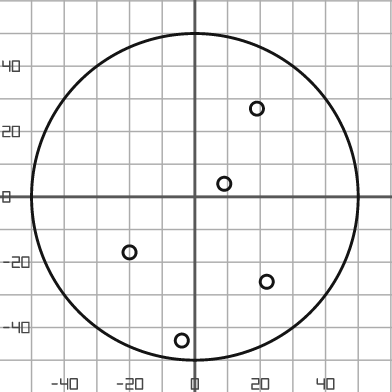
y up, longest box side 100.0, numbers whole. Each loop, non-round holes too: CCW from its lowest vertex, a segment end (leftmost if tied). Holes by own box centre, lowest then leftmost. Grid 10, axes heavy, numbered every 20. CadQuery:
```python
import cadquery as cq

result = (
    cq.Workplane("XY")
    .moveTo(0.0, 0.0)
    .circle(50.0)
    .moveTo(-4.0, -44.0)
    .circle(2.0)
    .moveTo(22.0, -26.0)
    .circle(2.0)
    .moveTo(-20.0, -17.0)
    .circle(2.0)
    .moveTo(9.0, 4.0)
    .circle(2.0)
    .moveTo(19.0, 27.0)
    .circle(2.0)
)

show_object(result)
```